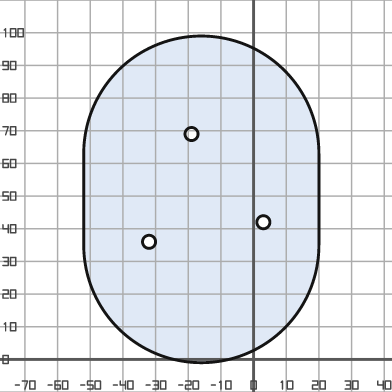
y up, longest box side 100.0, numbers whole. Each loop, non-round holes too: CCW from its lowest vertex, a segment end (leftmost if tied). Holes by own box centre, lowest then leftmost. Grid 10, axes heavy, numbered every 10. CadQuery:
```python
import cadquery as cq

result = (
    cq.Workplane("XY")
    .moveTo(-52.0, 35.0)
    .threePointArc((-16.0, -1.0), (20.0, 35.0))
    .lineTo(20.0, 63.0)
    .threePointArc((-16.0, 99.0), (-52.0, 63.0))
    .close()
    .moveTo(-32.0, 36.0)
    .circle(2.0)
    .moveTo(3.0, 42.0)
    .circle(2.0)
    .moveTo(-19.0, 69.0)
    .circle(2.0)
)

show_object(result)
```